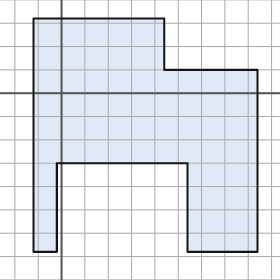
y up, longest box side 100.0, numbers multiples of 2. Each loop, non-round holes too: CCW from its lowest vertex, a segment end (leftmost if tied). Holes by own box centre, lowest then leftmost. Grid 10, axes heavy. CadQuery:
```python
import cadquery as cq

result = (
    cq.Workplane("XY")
    .moveTo(-12.0, -68.0)
    .lineTo(-2.0, -68.0)
    .lineTo(-2.0, -30.0)
    .lineTo(54.0, -30.0)
    .lineTo(54.0, -68.0)
    .lineTo(84.0, -68.0)
    .lineTo(84.0, 10.0)
    .lineTo(44.0, 10.0)
    .lineTo(44.0, 32.0)
    .lineTo(-12.0, 32.0)
    .close()
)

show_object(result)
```